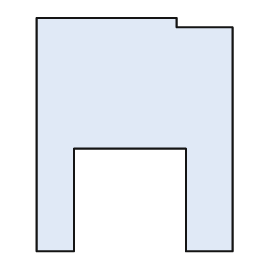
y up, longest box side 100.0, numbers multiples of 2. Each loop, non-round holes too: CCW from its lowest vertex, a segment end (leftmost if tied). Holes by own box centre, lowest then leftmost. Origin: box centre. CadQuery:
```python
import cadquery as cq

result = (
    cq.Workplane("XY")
    .moveTo(-42.0, -50.0)
    .lineTo(-26.0, -50.0)
    .lineTo(-26.0, -6.0)
    .lineTo(22.0, -6.0)
    .lineTo(22.0, -50.0)
    .lineTo(42.0, -50.0)
    .lineTo(42.0, 46.0)
    .lineTo(18.0, 46.0)
    .lineTo(18.0, 50.0)
    .lineTo(-42.0, 50.0)
    .close()
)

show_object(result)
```